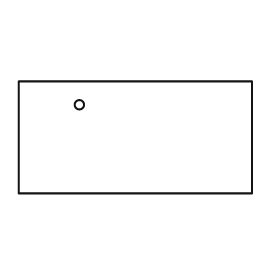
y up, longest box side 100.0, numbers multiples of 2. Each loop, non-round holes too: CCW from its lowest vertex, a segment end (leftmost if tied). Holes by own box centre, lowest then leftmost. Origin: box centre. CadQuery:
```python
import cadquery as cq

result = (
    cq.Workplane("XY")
    .moveTo(-50.0, -24.0)
    .lineTo(50.0, -24.0)
    .lineTo(50.0, 24.0)
    .lineTo(-50.0, 24.0)
    .close()
    .moveTo(-24.0, 14.0)
    .circle(2.0)
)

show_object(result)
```